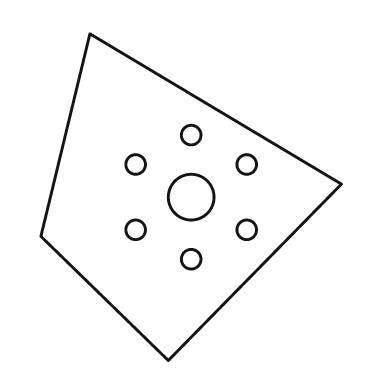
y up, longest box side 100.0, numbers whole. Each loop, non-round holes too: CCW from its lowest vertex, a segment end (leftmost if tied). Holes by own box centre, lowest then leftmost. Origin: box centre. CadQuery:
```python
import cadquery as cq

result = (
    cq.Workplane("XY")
    .moveTo(-7.0, -50.0)
    .lineTo(46.0, 4.0)
    .lineTo(-31.0, 50.0)
    .lineTo(-46.0, -12.0)
    .close()
    .moveTo(0.0, -19.0)
    .circle(3.0)
    .moveTo(-17.0, -10.0)
    .circle(3.0)
    .moveTo(17.0, -10.0)
    .circle(3.0)
    .moveTo(0.0, 0.0)
    .circle(7.0)
    .moveTo(-17.0, 10.0)
    .circle(3.0)
    .moveTo(17.0, 10.0)
    .circle(3.0)
    .moveTo(0.0, 19.0)
    .circle(3.0)
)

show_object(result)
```